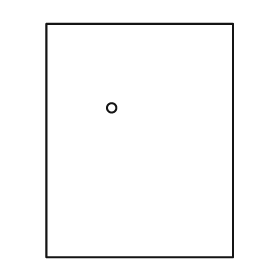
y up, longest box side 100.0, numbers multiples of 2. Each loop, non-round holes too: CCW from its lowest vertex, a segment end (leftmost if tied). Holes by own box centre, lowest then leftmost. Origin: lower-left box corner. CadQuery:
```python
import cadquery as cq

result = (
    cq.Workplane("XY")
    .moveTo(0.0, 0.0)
    .lineTo(80.0, 0.0)
    .lineTo(80.0, 100.0)
    .lineTo(0.0, 100.0)
    .close()
    .moveTo(28.0, 64.0)
    .circle(2.0)
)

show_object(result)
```